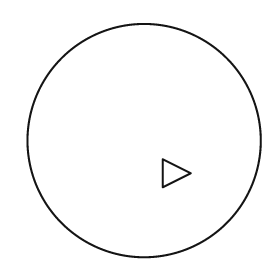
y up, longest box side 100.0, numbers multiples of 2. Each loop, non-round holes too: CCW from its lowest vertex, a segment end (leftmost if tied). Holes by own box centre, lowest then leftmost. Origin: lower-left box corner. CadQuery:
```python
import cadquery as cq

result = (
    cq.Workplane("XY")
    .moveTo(50.0, 50.0)
    .circle(50.0)
    .moveTo(58.0, 30.0)
    .lineTo(70.0, 36.0)
    .lineTo(58.0, 42.0)
    .close()
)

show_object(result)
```